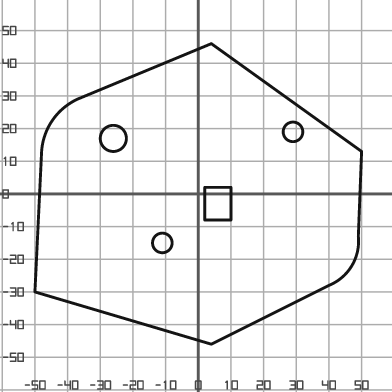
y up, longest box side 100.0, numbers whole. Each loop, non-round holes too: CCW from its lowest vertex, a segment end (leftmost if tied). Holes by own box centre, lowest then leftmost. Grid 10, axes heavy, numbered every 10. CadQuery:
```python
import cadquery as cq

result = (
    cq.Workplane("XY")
    .moveTo(4.0, -46.0)
    .lineTo(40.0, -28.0)
    .threePointArc((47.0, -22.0), (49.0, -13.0))
    .lineTo(50.0, 13.0)
    .lineTo(4.0, 46.0)
    .lineTo(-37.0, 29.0)
    .threePointArc((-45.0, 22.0), (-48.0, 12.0))
    .lineTo(-50.0, -30.0)
    .close()
    .moveTo(-11.0, -15.0)
    .circle(3.0)
    .moveTo(2.0, -8.0)
    .lineTo(10.0, -8.0)
    .lineTo(10.0, 2.0)
    .lineTo(2.0, 2.0)
    .close()
    .moveTo(-26.0, 17.0)
    .circle(4.0)
    .moveTo(29.0, 19.0)
    .circle(3.0)
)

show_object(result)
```